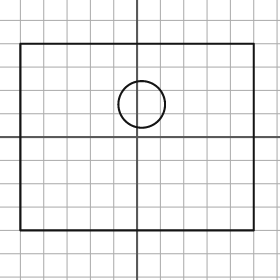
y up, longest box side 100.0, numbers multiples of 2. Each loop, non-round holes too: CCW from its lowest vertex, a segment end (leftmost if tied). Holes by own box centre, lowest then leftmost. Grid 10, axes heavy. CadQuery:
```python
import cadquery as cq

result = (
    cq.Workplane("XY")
    .moveTo(-50.0, -40.0)
    .lineTo(50.0, -40.0)
    .lineTo(50.0, 40.0)
    .lineTo(-50.0, 40.0)
    .close()
    .moveTo(2.0, 14.0)
    .circle(10.0)
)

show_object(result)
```